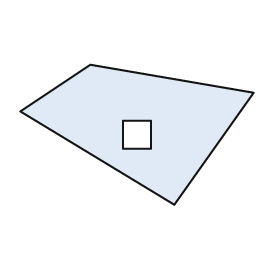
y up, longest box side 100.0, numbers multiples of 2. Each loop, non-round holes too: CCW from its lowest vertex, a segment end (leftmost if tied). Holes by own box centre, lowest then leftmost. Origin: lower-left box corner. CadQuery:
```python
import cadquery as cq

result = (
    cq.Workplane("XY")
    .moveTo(66.0, 0.0)
    .lineTo(100.0, 48.0)
    .lineTo(30.0, 60.0)
    .lineTo(0.0, 40.0)
    .close()
    .moveTo(44.0, 24.0)
    .lineTo(56.0, 24.0)
    .lineTo(56.0, 36.0)
    .lineTo(44.0, 36.0)
    .close()
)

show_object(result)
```